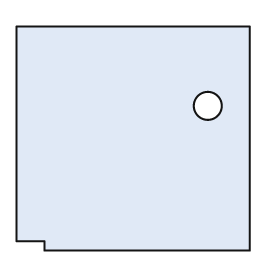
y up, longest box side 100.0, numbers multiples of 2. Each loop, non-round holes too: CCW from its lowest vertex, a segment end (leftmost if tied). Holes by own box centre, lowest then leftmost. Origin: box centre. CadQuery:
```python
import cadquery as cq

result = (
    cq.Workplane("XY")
    .moveTo(-38.0, -48.0)
    .lineTo(50.0, -48.0)
    .lineTo(50.0, 48.0)
    .lineTo(-50.0, 48.0)
    .lineTo(-50.0, -44.0)
    .lineTo(-38.0, -44.0)
    .close()
    .moveTo(32.0, 14.0)
    .circle(6.0)
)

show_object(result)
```